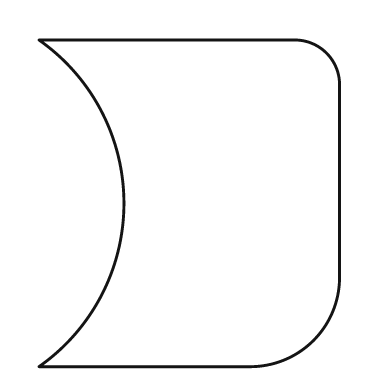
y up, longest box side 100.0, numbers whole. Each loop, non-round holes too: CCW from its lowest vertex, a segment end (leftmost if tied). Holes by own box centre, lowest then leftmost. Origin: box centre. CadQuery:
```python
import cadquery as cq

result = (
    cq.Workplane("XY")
    .moveTo(-46.0, -50.0)
    .lineTo(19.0, -50.0)
    .threePointArc((38.0, -42.0), (46.0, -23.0))
    .lineTo(46.0, 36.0)
    .threePointArc((42.0, 46.0), (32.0, 50.0))
    .lineTo(-46.0, 50.0)
    .threePointArc((-20.0, 0.0), (-46.0, -50.0))
    .close()
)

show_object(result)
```